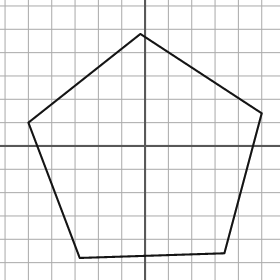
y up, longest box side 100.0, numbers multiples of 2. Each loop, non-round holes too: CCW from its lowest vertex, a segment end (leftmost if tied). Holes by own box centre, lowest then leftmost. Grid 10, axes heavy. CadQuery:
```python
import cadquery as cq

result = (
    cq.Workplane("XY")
    .moveTo(-28.0, -48.0)
    .lineTo(34.0, -46.0)
    .lineTo(50.0, 14.0)
    .lineTo(-2.0, 48.0)
    .lineTo(-50.0, 10.0)
    .close()
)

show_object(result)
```